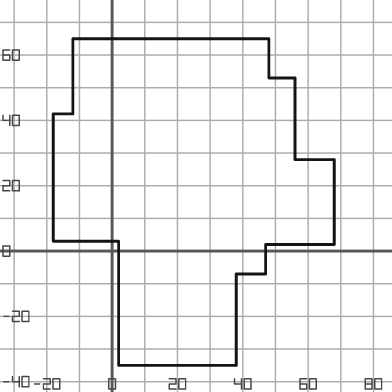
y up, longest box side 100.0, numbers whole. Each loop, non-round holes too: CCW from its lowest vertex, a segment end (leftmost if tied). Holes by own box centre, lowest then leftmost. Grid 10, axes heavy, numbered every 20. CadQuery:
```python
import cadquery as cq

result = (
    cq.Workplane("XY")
    .moveTo(2.0, -35.0)
    .lineTo(38.0, -35.0)
    .lineTo(38.0, -7.0)
    .lineTo(47.0, -7.0)
    .lineTo(47.0, 2.0)
    .lineTo(68.0, 2.0)
    .lineTo(68.0, 28.0)
    .lineTo(56.0, 28.0)
    .lineTo(56.0, 53.0)
    .lineTo(48.0, 53.0)
    .lineTo(48.0, 65.0)
    .lineTo(-12.0, 65.0)
    .lineTo(-12.0, 42.0)
    .lineTo(-18.0, 42.0)
    .lineTo(-18.0, 3.0)
    .lineTo(2.0, 3.0)
    .close()
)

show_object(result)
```